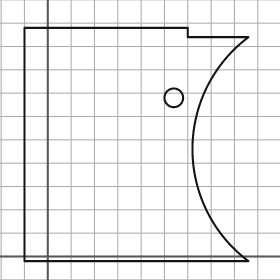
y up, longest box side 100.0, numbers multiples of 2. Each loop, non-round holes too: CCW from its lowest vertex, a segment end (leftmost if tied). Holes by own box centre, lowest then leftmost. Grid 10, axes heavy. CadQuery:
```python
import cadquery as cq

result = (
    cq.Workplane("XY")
    .moveTo(-10.0, -2.0)
    .lineTo(86.0, -2.0)
    .threePointArc((62.0, 46.0), (86.0, 94.0))
    .lineTo(60.0, 94.0)
    .lineTo(60.0, 98.0)
    .lineTo(-10.0, 98.0)
    .close()
    .moveTo(54.0, 68.0)
    .circle(4.0)
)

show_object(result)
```